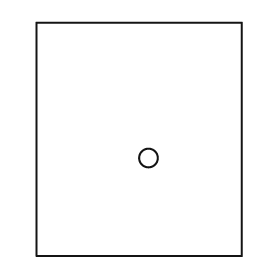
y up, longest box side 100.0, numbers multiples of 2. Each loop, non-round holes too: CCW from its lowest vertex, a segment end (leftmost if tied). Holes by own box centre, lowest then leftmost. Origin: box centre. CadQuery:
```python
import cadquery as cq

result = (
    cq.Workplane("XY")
    .moveTo(-44.0, -50.0)
    .lineTo(44.0, -50.0)
    .lineTo(44.0, 50.0)
    .lineTo(-44.0, 50.0)
    .close()
    .moveTo(4.0, -8.0)
    .circle(4.0)
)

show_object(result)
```